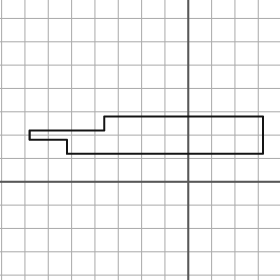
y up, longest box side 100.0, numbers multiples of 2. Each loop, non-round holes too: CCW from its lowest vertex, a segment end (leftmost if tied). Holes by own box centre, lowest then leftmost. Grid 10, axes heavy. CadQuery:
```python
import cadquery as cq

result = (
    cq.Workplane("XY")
    .moveTo(-52.0, 12.0)
    .lineTo(32.0, 12.0)
    .lineTo(32.0, 28.0)
    .lineTo(-36.0, 28.0)
    .lineTo(-36.0, 22.0)
    .lineTo(-68.0, 22.0)
    .lineTo(-68.0, 18.0)
    .lineTo(-52.0, 18.0)
    .close()
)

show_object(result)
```